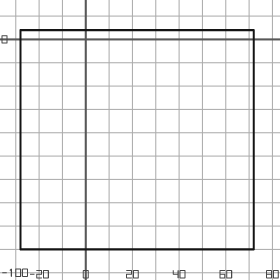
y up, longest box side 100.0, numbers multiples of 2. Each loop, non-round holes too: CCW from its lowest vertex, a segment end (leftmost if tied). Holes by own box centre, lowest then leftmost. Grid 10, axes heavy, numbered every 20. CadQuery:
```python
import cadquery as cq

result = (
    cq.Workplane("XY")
    .moveTo(-28.0, -90.0)
    .lineTo(72.0, -90.0)
    .lineTo(72.0, 4.0)
    .lineTo(-28.0, 4.0)
    .close()
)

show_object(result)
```